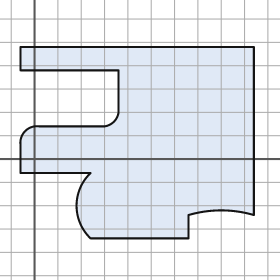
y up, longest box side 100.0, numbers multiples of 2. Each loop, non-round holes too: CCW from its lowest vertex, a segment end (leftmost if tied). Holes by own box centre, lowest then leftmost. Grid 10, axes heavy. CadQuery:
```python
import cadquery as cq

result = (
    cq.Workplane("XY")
    .moveTo(24.0, -34.0)
    .lineTo(66.0, -34.0)
    .lineTo(66.0, -24.0)
    .threePointArc((80.0, -22.0), (94.0, -24.0))
    .lineTo(94.0, 48.0)
    .lineTo(-6.0, 48.0)
    .lineTo(-6.0, 38.0)
    .lineTo(36.0, 38.0)
    .lineTo(36.0, 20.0)
    .threePointArc((34.0, 16.0), (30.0, 14.0))
    .lineTo(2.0, 14.0)
    .threePointArc((-4.0, 12.0), (-6.0, 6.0))
    .lineTo(-6.0, -6.0)
    .lineTo(24.0, -6.0)
    .threePointArc((18.0, -20.0), (24.0, -34.0))
    .close()
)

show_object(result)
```